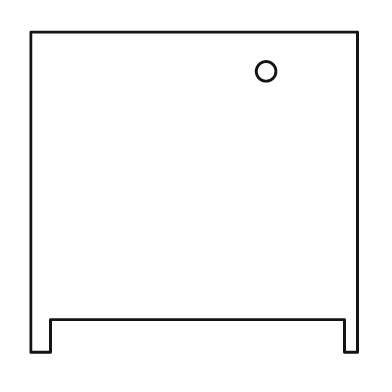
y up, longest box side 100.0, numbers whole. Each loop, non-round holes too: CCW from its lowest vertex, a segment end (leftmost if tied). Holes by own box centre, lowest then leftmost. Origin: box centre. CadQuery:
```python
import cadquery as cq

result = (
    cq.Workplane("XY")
    .moveTo(-50.0, -49.0)
    .lineTo(-44.0, -49.0)
    .lineTo(-44.0, -39.0)
    .lineTo(46.0, -39.0)
    .lineTo(46.0, -49.0)
    .lineTo(50.0, -49.0)
    .lineTo(50.0, 49.0)
    .lineTo(-50.0, 49.0)
    .close()
    .moveTo(22.0, 37.0)
    .circle(3.0)
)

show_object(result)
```